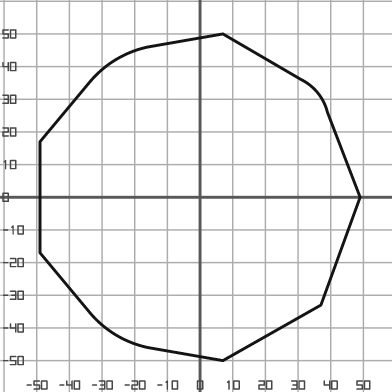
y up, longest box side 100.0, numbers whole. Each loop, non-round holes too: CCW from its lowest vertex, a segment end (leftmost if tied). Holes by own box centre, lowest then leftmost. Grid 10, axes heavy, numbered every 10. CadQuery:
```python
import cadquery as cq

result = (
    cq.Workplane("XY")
    .moveTo(7.0, -50.0)
    .lineTo(37.0, -33.0)
    .lineTo(49.0, 0.0)
    .lineTo(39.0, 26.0)
    .threePointArc((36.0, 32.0), (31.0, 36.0))
    .lineTo(7.0, 50.0)
    .lineTo(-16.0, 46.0)
    .threePointArc((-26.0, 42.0), (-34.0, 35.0))
    .lineTo(-49.0, 17.0)
    .lineTo(-49.0, -17.0)
    .lineTo(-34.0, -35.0)
    .threePointArc((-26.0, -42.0), (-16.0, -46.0))
    .close()
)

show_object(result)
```